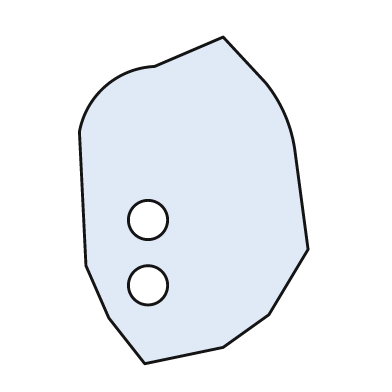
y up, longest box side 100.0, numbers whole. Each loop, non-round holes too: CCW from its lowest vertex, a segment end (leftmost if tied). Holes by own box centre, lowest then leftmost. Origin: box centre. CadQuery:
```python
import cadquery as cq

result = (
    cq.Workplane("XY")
    .moveTo(-15.0, -50.0)
    .lineTo(9.0, -45.0)
    .lineTo(23.0, -35.0)
    .lineTo(35.0, -15.0)
    .lineTo(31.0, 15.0)
    .threePointArc((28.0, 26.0), (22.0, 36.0))
    .lineTo(9.0, 50.0)
    .lineTo(-12.0, 41.0)
    .threePointArc((-27.0, 35.0), (-35.0, 21.0))
    .lineTo(-33.0, -20.0)
    .lineTo(-26.0, -36.0)
    .close()
    .moveTo(-14.0, -26.0)
    .circle(6.0)
    .moveTo(-14.0, -6.0)
    .circle(6.0)
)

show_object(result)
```